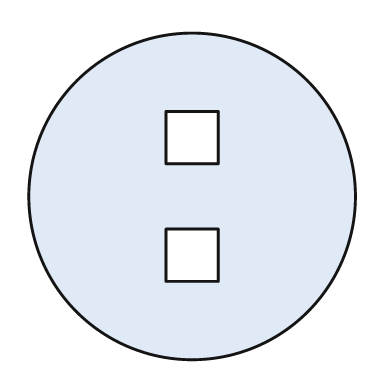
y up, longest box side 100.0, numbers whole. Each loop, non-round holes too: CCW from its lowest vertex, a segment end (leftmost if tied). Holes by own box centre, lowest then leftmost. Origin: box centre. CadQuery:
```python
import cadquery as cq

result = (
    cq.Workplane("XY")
    .moveTo(0.0, 0.0)
    .circle(50.0)
    .moveTo(-8.0, -26.0)
    .lineTo(8.0, -26.0)
    .lineTo(8.0, -10.0)
    .lineTo(-8.0, -10.0)
    .close()
    .moveTo(-8.0, 10.0)
    .lineTo(8.0, 10.0)
    .lineTo(8.0, 26.0)
    .lineTo(-8.0, 26.0)
    .close()
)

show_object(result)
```